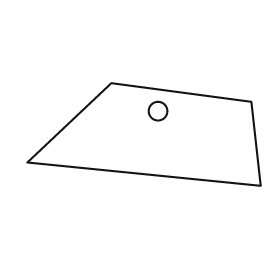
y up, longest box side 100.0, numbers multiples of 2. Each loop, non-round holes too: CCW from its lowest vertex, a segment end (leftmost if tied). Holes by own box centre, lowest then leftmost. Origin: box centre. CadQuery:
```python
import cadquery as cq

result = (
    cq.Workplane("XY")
    .moveTo(50.0, -22.0)
    .lineTo(46.0, 14.0)
    .lineTo(-14.0, 22.0)
    .lineTo(-50.0, -12.0)
    .close()
    .moveTo(6.0, 10.0)
    .circle(4.0)
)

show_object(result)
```